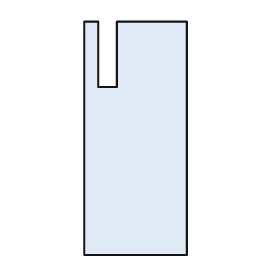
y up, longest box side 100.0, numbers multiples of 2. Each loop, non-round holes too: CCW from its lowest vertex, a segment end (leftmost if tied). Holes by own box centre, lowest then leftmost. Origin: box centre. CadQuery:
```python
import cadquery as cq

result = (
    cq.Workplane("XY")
    .moveTo(-22.0, -50.0)
    .lineTo(22.0, -50.0)
    .lineTo(22.0, 50.0)
    .lineTo(-8.0, 50.0)
    .lineTo(-8.0, 22.0)
    .lineTo(-16.0, 22.0)
    .lineTo(-16.0, 50.0)
    .lineTo(-22.0, 50.0)
    .close()
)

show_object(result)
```